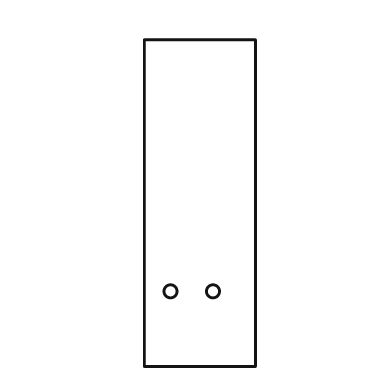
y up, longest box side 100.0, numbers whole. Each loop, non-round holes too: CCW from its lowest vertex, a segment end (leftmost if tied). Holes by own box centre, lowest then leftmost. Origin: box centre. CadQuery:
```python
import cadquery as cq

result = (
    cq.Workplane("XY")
    .moveTo(-17.0, -50.0)
    .lineTo(17.0, -50.0)
    .lineTo(17.0, 50.0)
    .lineTo(-17.0, 50.0)
    .close()
    .moveTo(-9.0, -27.0)
    .circle(2.0)
    .moveTo(4.0, -27.0)
    .circle(2.0)
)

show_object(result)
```